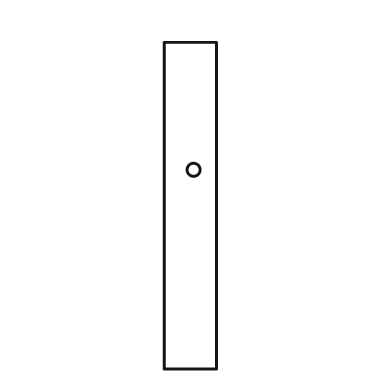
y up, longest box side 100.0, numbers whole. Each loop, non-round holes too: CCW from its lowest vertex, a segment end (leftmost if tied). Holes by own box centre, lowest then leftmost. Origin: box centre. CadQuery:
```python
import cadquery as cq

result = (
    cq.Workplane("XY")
    .moveTo(-8.0, -50.0)
    .lineTo(8.0, -50.0)
    .lineTo(8.0, 50.0)
    .lineTo(-8.0, 50.0)
    .close()
    .moveTo(1.0, 11.0)
    .circle(2.0)
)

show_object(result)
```